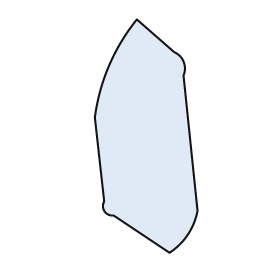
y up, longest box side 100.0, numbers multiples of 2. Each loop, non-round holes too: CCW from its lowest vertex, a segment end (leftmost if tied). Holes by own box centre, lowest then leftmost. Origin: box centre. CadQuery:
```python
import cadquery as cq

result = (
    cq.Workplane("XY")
    .moveTo(10.0, -50.0)
    .threePointArc((18.0, -42.0), (22.0, -32.0))
    .lineTo(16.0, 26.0)
    .threePointArc((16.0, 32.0), (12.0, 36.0))
    .lineTo(-4.0, 50.0)
    .threePointArc((-16.0, 30.0), (-22.0, 8.0))
    .lineTo(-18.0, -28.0)
    .threePointArc((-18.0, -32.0), (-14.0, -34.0))
    .close()
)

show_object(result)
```